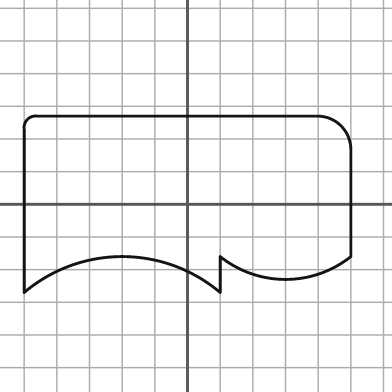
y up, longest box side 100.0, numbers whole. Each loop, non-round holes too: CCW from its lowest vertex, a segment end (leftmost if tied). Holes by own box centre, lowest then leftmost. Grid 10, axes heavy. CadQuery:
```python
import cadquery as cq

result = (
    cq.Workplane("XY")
    .moveTo(-50.0, -27.0)
    .threePointArc((-20.0, -16.0), (10.0, -27.0))
    .lineTo(10.0, -16.0)
    .threePointArc((30.0, -23.0), (50.0, -16.0))
    .lineTo(50.0, 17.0)
    .threePointArc((47.0, 24.0), (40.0, 27.0))
    .lineTo(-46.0, 27.0)
    .threePointArc((-49.0, 26.0), (-50.0, 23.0))
    .close()
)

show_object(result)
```